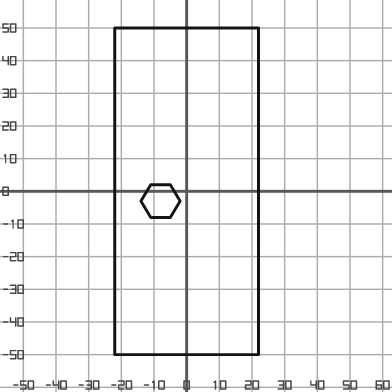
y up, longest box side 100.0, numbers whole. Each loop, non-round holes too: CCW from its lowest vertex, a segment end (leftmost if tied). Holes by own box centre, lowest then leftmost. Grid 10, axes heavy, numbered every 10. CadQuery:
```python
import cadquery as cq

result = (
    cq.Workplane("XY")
    .moveTo(-22.0, -50.0)
    .lineTo(22.0, -50.0)
    .lineTo(22.0, 50.0)
    .lineTo(-22.0, 50.0)
    .close()
    .moveTo(-11.0, -8.0)
    .lineTo(-5.0, -8.0)
    .lineTo(-2.0, -3.0)
    .lineTo(-5.0, 2.0)
    .lineTo(-11.0, 2.0)
    .lineTo(-14.0, -3.0)
    .close()
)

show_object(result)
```